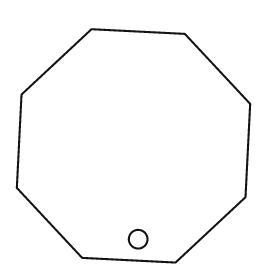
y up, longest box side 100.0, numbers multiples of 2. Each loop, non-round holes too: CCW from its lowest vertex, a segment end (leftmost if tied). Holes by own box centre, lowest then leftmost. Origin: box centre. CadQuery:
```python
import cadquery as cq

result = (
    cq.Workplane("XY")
    .moveTo(18.0, -50.0)
    .lineTo(48.0, -22.0)
    .lineTo(50.0, 18.0)
    .lineTo(22.0, 48.0)
    .lineTo(-18.0, 50.0)
    .lineTo(-48.0, 22.0)
    .lineTo(-50.0, -18.0)
    .lineTo(-22.0, -48.0)
    .close()
    .moveTo(2.0, -40.0)
    .circle(4.0)
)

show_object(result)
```